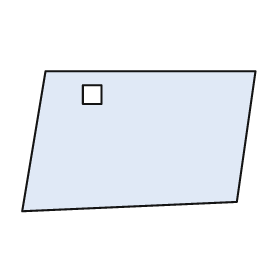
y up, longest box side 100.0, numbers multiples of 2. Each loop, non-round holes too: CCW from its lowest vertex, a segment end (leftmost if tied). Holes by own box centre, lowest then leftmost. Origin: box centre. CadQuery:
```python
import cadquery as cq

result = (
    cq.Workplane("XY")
    .moveTo(-50.0, -30.0)
    .lineTo(42.0, -26.0)
    .lineTo(50.0, 30.0)
    .lineTo(-40.0, 30.0)
    .close()
    .moveTo(-24.0, 16.0)
    .lineTo(-16.0, 16.0)
    .lineTo(-16.0, 24.0)
    .lineTo(-24.0, 24.0)
    .close()
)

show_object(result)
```